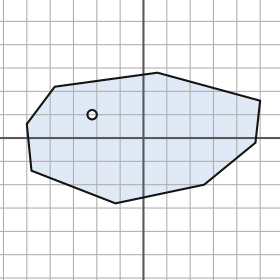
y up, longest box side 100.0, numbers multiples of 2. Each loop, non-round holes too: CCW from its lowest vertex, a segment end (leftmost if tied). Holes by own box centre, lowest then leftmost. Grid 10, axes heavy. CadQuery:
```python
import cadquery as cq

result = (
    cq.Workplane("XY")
    .moveTo(-12.0, -28.0)
    .lineTo(26.0, -20.0)
    .lineTo(48.0, -2.0)
    .lineTo(50.0, 16.0)
    .lineTo(6.0, 28.0)
    .lineTo(-38.0, 22.0)
    .lineTo(-50.0, 6.0)
    .lineTo(-48.0, -14.0)
    .close()
    .moveTo(-22.0, 10.0)
    .circle(2.0)
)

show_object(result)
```